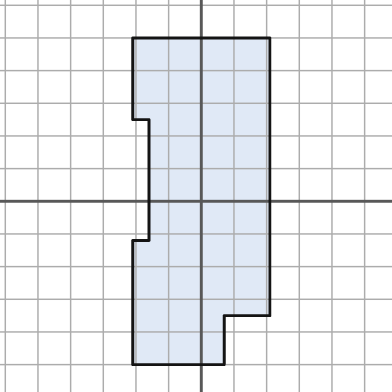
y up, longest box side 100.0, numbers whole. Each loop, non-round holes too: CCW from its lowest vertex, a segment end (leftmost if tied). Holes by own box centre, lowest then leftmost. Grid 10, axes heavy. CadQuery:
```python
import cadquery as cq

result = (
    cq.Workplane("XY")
    .moveTo(-21.0, -50.0)
    .lineTo(7.0, -50.0)
    .lineTo(7.0, -35.0)
    .lineTo(21.0, -35.0)
    .lineTo(21.0, 50.0)
    .lineTo(-21.0, 50.0)
    .lineTo(-21.0, 25.0)
    .lineTo(-16.0, 25.0)
    .lineTo(-16.0, -12.0)
    .lineTo(-21.0, -12.0)
    .close()
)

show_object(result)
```